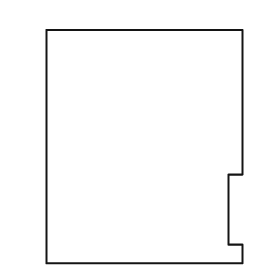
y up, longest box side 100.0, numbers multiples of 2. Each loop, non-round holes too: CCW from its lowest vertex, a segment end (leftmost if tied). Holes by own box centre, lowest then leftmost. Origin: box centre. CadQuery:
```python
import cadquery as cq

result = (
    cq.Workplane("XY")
    .moveTo(-42.0, -50.0)
    .lineTo(42.0, -50.0)
    .lineTo(42.0, -42.0)
    .lineTo(36.0, -42.0)
    .lineTo(36.0, -12.0)
    .lineTo(42.0, -12.0)
    .lineTo(42.0, 50.0)
    .lineTo(-42.0, 50.0)
    .close()
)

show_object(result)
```